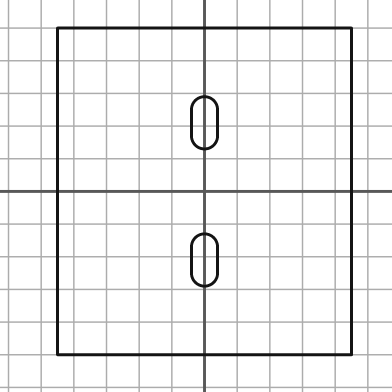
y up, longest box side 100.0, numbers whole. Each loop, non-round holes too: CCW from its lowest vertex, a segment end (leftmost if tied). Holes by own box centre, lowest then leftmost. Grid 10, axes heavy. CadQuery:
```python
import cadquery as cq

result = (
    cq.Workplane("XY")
    .moveTo(-45.0, -50.0)
    .lineTo(45.0, -50.0)
    .lineTo(45.0, 50.0)
    .lineTo(-45.0, 50.0)
    .close()
    .moveTo(-4.0, -25.0)
    .threePointArc((0.0, -29.0), (4.0, -25.0))
    .lineTo(4.0, -17.0)
    .threePointArc((0.0, -13.0), (-4.0, -17.0))
    .close()
    .moveTo(-4.0, 17.0)
    .threePointArc((0.0, 13.0), (4.0, 17.0))
    .lineTo(4.0, 25.0)
    .threePointArc((0.0, 29.0), (-4.0, 25.0))
    .close()
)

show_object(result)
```